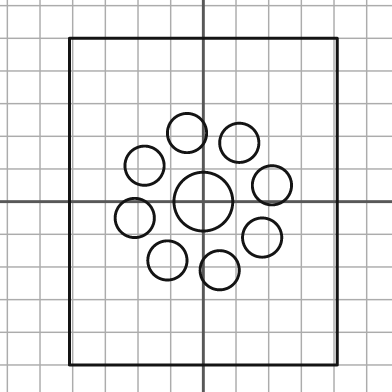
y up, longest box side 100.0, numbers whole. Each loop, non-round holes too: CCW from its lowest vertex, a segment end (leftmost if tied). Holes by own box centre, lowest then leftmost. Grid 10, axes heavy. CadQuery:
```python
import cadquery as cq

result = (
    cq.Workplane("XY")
    .moveTo(-41.0, -50.0)
    .lineTo(41.0, -50.0)
    .lineTo(41.0, 50.0)
    .lineTo(-41.0, 50.0)
    .close()
    .moveTo(5.0, -21.0)
    .circle(6.0)
    .moveTo(-11.0, -18.0)
    .circle(6.0)
    .moveTo(18.0, -11.0)
    .circle(6.0)
    .moveTo(-21.0, -5.0)
    .circle(6.0)
    .moveTo(0.0, 0.0)
    .circle(9.0)
    .moveTo(21.0, 5.0)
    .circle(6.0)
    .moveTo(-18.0, 11.0)
    .circle(6.0)
    .moveTo(11.0, 18.0)
    .circle(6.0)
    .moveTo(-5.0, 21.0)
    .circle(6.0)
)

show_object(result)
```